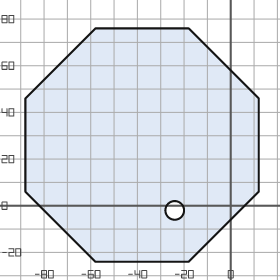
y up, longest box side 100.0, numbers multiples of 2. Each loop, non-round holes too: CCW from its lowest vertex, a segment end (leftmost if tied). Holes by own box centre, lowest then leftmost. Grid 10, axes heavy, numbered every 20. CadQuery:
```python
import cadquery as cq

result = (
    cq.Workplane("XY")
    .moveTo(-58.0, -24.0)
    .lineTo(-18.0, -24.0)
    .lineTo(12.0, 6.0)
    .lineTo(12.0, 46.0)
    .lineTo(-18.0, 76.0)
    .lineTo(-58.0, 76.0)
    .lineTo(-88.0, 46.0)
    .lineTo(-88.0, 6.0)
    .close()
    .moveTo(-24.0, -2.0)
    .circle(4.0)
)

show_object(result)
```